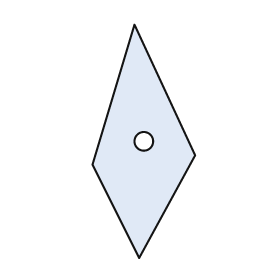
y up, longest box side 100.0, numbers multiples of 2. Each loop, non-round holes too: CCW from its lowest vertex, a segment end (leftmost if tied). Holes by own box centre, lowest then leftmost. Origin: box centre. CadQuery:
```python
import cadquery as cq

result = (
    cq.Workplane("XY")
    .moveTo(-2.0, -50.0)
    .lineTo(22.0, -6.0)
    .lineTo(-4.0, 50.0)
    .lineTo(-22.0, -10.0)
    .close()
    .moveTo(0.0, 0.0)
    .circle(4.0)
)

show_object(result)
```